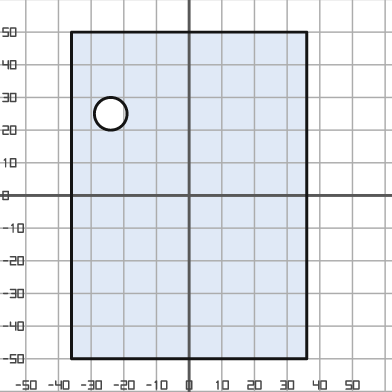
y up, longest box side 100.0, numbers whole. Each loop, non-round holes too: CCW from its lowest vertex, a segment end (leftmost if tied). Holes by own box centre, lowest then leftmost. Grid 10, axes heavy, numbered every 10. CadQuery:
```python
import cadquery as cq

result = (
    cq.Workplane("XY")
    .moveTo(-36.0, -50.0)
    .lineTo(36.0, -50.0)
    .lineTo(36.0, 50.0)
    .lineTo(-36.0, 50.0)
    .close()
    .moveTo(-24.0, 25.0)
    .circle(5.0)
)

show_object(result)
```